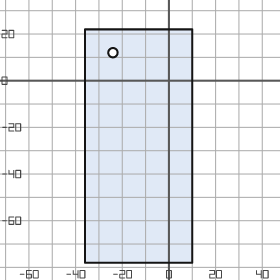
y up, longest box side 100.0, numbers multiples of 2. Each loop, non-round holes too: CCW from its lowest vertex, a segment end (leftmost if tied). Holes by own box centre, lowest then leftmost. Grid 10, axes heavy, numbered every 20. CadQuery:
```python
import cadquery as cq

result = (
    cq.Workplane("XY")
    .moveTo(-36.0, -78.0)
    .lineTo(10.0, -78.0)
    .lineTo(10.0, 22.0)
    .lineTo(-36.0, 22.0)
    .close()
    .moveTo(-24.0, 12.0)
    .circle(2.0)
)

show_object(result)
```